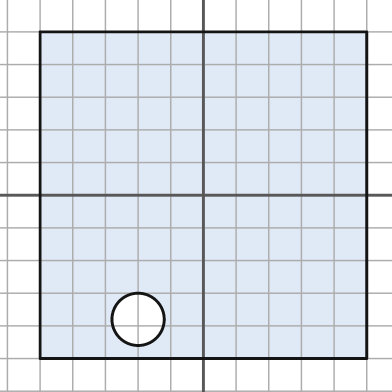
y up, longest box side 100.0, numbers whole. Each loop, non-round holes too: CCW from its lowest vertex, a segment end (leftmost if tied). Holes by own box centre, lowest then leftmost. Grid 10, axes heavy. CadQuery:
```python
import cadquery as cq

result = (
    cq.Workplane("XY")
    .moveTo(-50.0, -50.0)
    .lineTo(50.0, -50.0)
    .lineTo(50.0, 50.0)
    .lineTo(-50.0, 50.0)
    .close()
    .moveTo(-20.0, -38.0)
    .circle(8.0)
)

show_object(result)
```